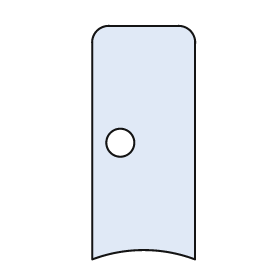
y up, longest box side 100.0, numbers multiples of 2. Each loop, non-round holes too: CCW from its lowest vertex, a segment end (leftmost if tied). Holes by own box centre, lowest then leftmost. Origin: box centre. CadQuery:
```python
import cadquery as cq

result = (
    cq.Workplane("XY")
    .moveTo(-22.0, -50.0)
    .threePointArc((0.0, -46.0), (22.0, -50.0))
    .lineTo(22.0, 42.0)
    .threePointArc((20.0, 48.0), (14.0, 50.0))
    .lineTo(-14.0, 50.0)
    .threePointArc((-20.0, 48.0), (-22.0, 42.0))
    .close()
    .moveTo(-10.0, 0.0)
    .circle(6.0)
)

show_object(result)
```